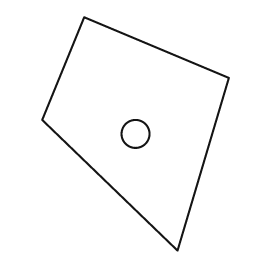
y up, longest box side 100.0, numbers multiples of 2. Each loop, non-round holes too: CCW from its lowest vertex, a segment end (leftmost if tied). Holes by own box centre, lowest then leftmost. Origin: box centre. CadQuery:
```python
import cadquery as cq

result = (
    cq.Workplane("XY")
    .moveTo(18.0, -50.0)
    .lineTo(40.0, 24.0)
    .lineTo(-22.0, 50.0)
    .lineTo(-40.0, 6.0)
    .close()
    .moveTo(0.0, 0.0)
    .circle(6.0)
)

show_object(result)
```